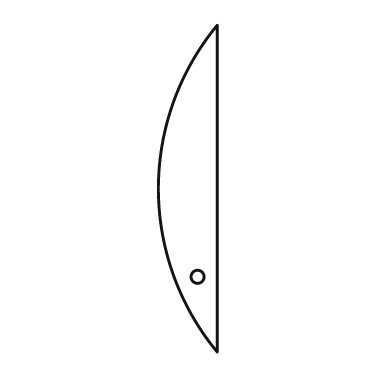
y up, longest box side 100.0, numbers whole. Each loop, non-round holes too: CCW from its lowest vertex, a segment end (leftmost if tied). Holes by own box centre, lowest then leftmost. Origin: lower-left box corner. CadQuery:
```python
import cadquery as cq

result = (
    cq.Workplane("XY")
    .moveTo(18.0, 0.0)
    .lineTo(18.0, 100.0)
    .threePointArc((0.0, 50.0), (18.0, 0.0))
    .close()
    .moveTo(12.0, 23.0)
    .circle(2.0)
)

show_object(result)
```